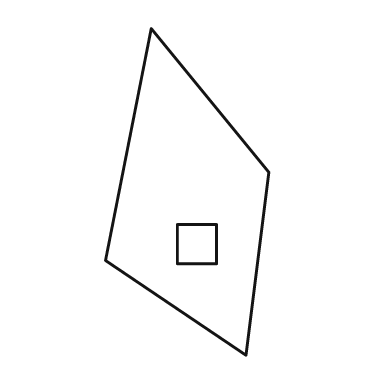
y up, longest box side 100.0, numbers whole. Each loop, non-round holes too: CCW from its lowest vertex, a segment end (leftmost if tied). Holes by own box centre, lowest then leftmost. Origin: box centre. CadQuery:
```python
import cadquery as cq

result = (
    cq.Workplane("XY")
    .moveTo(18.0, -50.0)
    .lineTo(25.0, 6.0)
    .lineTo(-11.0, 50.0)
    .lineTo(-25.0, -21.0)
    .close()
    .moveTo(-3.0, -22.0)
    .lineTo(9.0, -22.0)
    .lineTo(9.0, -10.0)
    .lineTo(-3.0, -10.0)
    .close()
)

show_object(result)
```